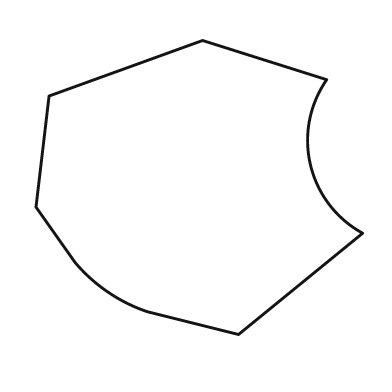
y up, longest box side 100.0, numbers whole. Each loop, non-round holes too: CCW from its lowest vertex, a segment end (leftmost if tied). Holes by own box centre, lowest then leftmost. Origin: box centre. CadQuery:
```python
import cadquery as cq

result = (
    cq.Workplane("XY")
    .moveTo(12.0, -45.0)
    .lineTo(50.0, -14.0)
    .threePointArc((34.0, 7.0), (39.0, 33.0))
    .lineTo(1.0, 45.0)
    .lineTo(-46.0, 28.0)
    .lineTo(-50.0, -6.0)
    .lineTo(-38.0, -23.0)
    .threePointArc((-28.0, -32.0), (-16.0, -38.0))
    .close()
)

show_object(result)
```